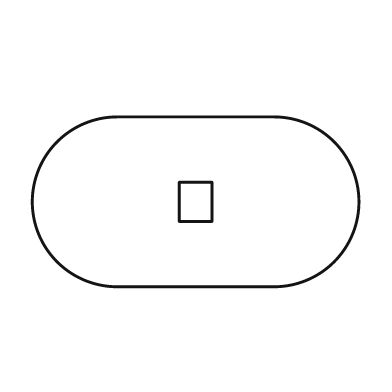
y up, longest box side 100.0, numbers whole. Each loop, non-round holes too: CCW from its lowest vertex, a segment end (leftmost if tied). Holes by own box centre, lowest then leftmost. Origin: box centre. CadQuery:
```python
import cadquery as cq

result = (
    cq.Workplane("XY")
    .moveTo(-24.0, -26.0)
    .lineTo(24.0, -26.0)
    .threePointArc((50.0, 0.0), (24.0, 26.0))
    .lineTo(-24.0, 26.0)
    .threePointArc((-50.0, 0.0), (-24.0, -26.0))
    .close()
    .moveTo(-5.0, -6.0)
    .lineTo(5.0, -6.0)
    .lineTo(5.0, 6.0)
    .lineTo(-5.0, 6.0)
    .close()
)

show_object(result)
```